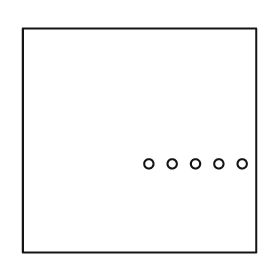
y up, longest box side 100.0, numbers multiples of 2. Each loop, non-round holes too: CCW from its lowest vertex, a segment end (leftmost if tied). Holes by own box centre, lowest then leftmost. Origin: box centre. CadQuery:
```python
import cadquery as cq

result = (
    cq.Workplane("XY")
    .moveTo(-50.0, -48.0)
    .lineTo(50.0, -48.0)
    .lineTo(50.0, 48.0)
    .lineTo(-50.0, 48.0)
    .close()
    .moveTo(4.0, -10.0)
    .circle(2.0)
    .moveTo(14.0, -10.0)
    .circle(2.0)
    .moveTo(24.0, -10.0)
    .circle(2.0)
    .moveTo(34.0, -10.0)
    .circle(2.0)
    .moveTo(44.0, -10.0)
    .circle(2.0)
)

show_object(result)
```